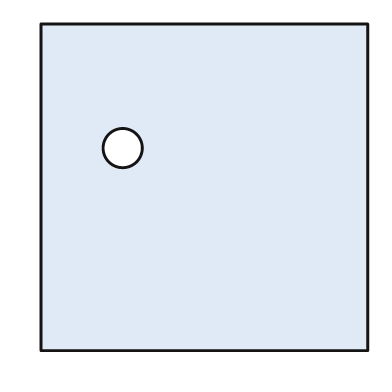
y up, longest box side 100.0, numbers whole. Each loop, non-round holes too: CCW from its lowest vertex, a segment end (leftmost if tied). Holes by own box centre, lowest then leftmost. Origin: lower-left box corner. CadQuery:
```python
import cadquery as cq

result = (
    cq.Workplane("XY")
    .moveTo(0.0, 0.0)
    .lineTo(100.0, 0.0)
    .lineTo(100.0, 100.0)
    .lineTo(0.0, 100.0)
    .close()
    .moveTo(25.0, 62.0)
    .circle(6.0)
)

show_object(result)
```